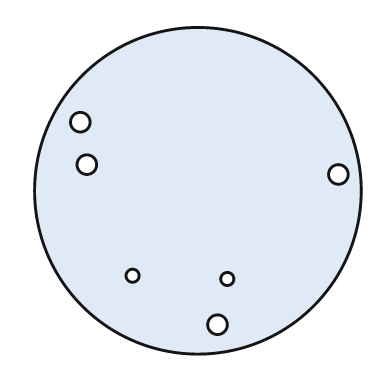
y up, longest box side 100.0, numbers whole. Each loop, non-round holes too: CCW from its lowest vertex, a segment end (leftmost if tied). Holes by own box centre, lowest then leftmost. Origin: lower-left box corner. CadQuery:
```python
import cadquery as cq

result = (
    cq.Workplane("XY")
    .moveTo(50.0, 50.0)
    .circle(50.0)
    .moveTo(56.0, 9.0)
    .circle(3.0)
    .moveTo(59.0, 23.0)
    .circle(2.0)
    .moveTo(30.0, 24.0)
    .circle(2.0)
    .moveTo(93.0, 55.0)
    .circle(3.0)
    .moveTo(16.0, 58.0)
    .circle(3.0)
    .moveTo(14.0, 71.0)
    .circle(3.0)
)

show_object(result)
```